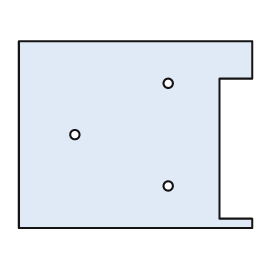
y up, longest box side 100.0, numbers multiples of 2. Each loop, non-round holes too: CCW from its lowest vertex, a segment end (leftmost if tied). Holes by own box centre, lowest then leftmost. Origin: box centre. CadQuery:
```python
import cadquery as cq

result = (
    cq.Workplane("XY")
    .moveTo(-50.0, -40.0)
    .lineTo(50.0, -40.0)
    .lineTo(50.0, -36.0)
    .lineTo(36.0, -36.0)
    .lineTo(36.0, 24.0)
    .lineTo(50.0, 24.0)
    .lineTo(50.0, 40.0)
    .lineTo(-50.0, 40.0)
    .close()
    .moveTo(14.0, -22.0)
    .circle(2.0)
    .moveTo(-26.0, 0.0)
    .circle(2.0)
    .moveTo(14.0, 22.0)
    .circle(2.0)
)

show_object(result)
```